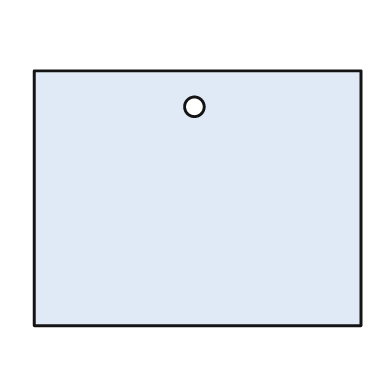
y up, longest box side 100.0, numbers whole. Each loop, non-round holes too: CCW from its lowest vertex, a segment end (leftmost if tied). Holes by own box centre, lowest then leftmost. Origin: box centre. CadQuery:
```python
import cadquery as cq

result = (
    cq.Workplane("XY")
    .moveTo(-50.0, -39.0)
    .lineTo(50.0, -39.0)
    .lineTo(50.0, 39.0)
    .lineTo(-50.0, 39.0)
    .close()
    .moveTo(-1.0, 28.0)
    .circle(3.0)
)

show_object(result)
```